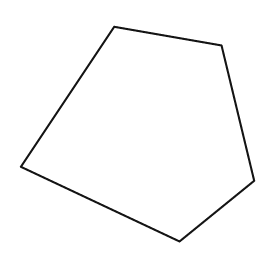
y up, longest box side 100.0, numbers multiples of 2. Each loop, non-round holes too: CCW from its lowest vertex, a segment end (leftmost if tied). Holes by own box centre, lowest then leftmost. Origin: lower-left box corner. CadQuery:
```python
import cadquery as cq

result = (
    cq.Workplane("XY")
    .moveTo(68.0, 0.0)
    .lineTo(100.0, 26.0)
    .lineTo(86.0, 84.0)
    .lineTo(40.0, 92.0)
    .lineTo(0.0, 32.0)
    .close()
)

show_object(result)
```